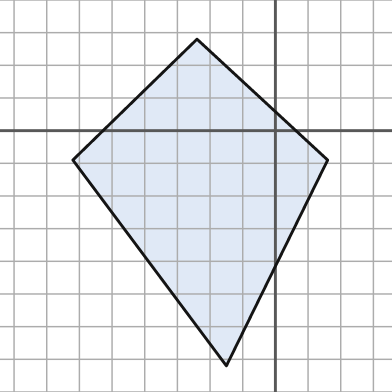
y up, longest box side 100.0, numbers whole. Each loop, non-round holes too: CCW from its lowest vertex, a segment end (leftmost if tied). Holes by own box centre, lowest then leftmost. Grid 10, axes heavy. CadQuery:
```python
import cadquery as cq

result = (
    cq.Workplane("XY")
    .moveTo(-15.0, -72.0)
    .lineTo(16.0, -9.0)
    .lineTo(-24.0, 28.0)
    .lineTo(-62.0, -9.0)
    .close()
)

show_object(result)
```